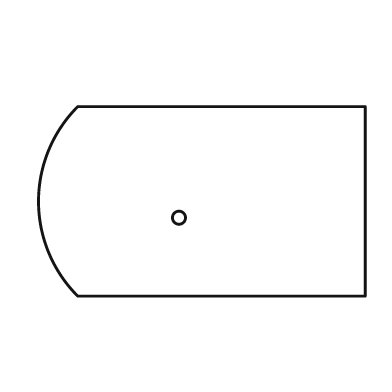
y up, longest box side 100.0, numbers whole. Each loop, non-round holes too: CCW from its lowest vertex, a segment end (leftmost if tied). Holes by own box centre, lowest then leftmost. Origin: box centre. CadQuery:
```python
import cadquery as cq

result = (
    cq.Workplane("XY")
    .moveTo(-38.0, -29.0)
    .lineTo(50.0, -29.0)
    .lineTo(50.0, 29.0)
    .lineTo(-38.0, 29.0)
    .threePointArc((-50.0, 0.0), (-38.0, -29.0))
    .close()
    .moveTo(-7.0, -5.0)
    .circle(2.0)
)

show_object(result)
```